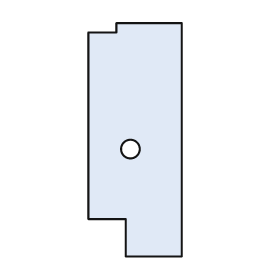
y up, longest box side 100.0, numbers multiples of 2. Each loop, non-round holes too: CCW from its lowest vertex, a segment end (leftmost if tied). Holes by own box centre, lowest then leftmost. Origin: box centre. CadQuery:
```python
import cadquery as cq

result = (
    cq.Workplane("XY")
    .moveTo(-4.0, -50.0)
    .lineTo(20.0, -50.0)
    .lineTo(20.0, 50.0)
    .lineTo(-8.0, 50.0)
    .lineTo(-8.0, 46.0)
    .lineTo(-20.0, 46.0)
    .lineTo(-20.0, -34.0)
    .lineTo(-4.0, -34.0)
    .close()
    .moveTo(-2.0, -4.0)
    .circle(4.0)
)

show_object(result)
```